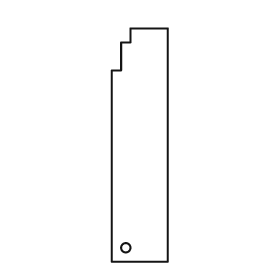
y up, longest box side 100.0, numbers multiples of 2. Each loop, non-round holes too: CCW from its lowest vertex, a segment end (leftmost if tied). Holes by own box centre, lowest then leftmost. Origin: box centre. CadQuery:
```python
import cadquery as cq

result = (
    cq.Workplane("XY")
    .moveTo(-12.0, -50.0)
    .lineTo(12.0, -50.0)
    .lineTo(12.0, 50.0)
    .lineTo(-4.0, 50.0)
    .lineTo(-4.0, 44.0)
    .lineTo(-8.0, 44.0)
    .lineTo(-8.0, 32.0)
    .lineTo(-12.0, 32.0)
    .close()
    .moveTo(-6.0, -44.0)
    .circle(2.0)
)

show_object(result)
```